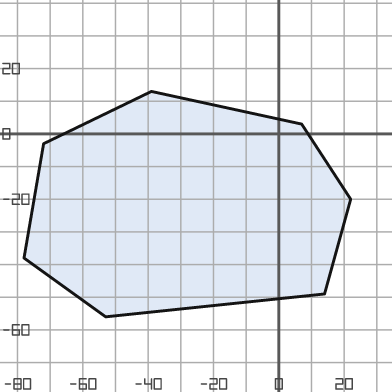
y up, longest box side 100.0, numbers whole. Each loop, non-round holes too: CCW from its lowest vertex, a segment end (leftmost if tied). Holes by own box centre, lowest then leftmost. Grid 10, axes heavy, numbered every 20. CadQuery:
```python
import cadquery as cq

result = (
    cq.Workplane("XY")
    .moveTo(-53.0, -56.0)
    .lineTo(14.0, -49.0)
    .lineTo(22.0, -20.0)
    .lineTo(7.0, 3.0)
    .lineTo(-39.0, 13.0)
    .lineTo(-72.0, -3.0)
    .lineTo(-78.0, -38.0)
    .close()
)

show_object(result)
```